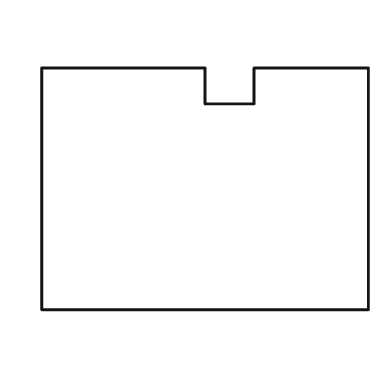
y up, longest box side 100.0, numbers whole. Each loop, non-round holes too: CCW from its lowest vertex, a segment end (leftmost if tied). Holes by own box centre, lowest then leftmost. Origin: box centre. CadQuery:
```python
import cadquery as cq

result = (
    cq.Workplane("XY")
    .moveTo(-50.0, -37.0)
    .lineTo(50.0, -37.0)
    .lineTo(50.0, 37.0)
    .lineTo(15.0, 37.0)
    .lineTo(15.0, 26.0)
    .lineTo(0.0, 26.0)
    .lineTo(0.0, 37.0)
    .lineTo(-50.0, 37.0)
    .close()
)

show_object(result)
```